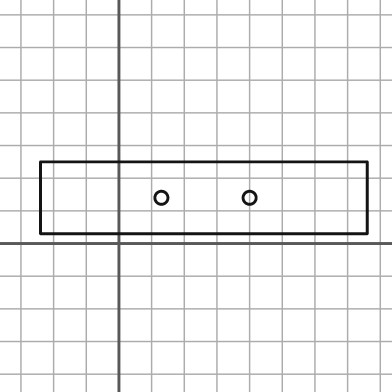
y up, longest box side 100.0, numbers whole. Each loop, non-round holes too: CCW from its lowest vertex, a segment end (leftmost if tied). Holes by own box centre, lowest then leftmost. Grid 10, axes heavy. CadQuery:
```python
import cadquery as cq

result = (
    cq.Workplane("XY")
    .moveTo(-24.0, 3.0)
    .lineTo(76.0, 3.0)
    .lineTo(76.0, 25.0)
    .lineTo(-24.0, 25.0)
    .close()
    .moveTo(13.0, 14.0)
    .circle(2.0)
    .moveTo(40.0, 14.0)
    .circle(2.0)
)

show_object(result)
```